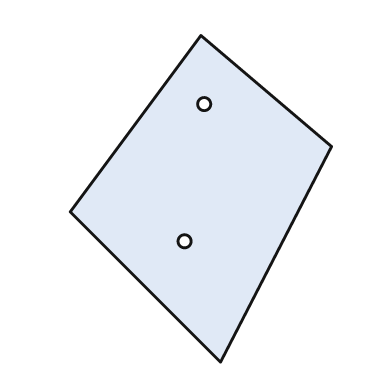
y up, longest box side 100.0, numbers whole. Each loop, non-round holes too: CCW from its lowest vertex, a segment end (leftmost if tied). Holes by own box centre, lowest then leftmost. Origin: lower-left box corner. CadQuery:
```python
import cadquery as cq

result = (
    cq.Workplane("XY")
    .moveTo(46.0, 0.0)
    .lineTo(80.0, 66.0)
    .lineTo(40.0, 100.0)
    .lineTo(0.0, 46.0)
    .close()
    .moveTo(35.0, 37.0)
    .circle(2.0)
    .moveTo(41.0, 79.0)
    .circle(2.0)
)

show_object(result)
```